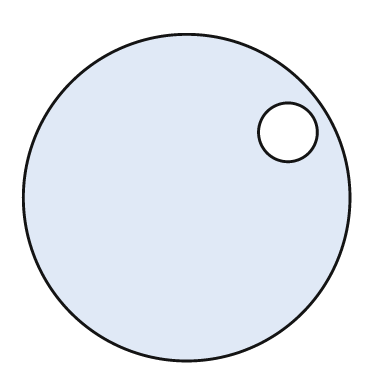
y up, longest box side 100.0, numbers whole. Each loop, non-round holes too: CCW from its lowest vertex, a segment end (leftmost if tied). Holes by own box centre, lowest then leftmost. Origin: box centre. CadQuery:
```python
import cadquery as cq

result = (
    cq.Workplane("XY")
    .moveTo(0.0, 0.0)
    .circle(50.0)
    .moveTo(31.0, 20.0)
    .circle(9.0)
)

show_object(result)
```